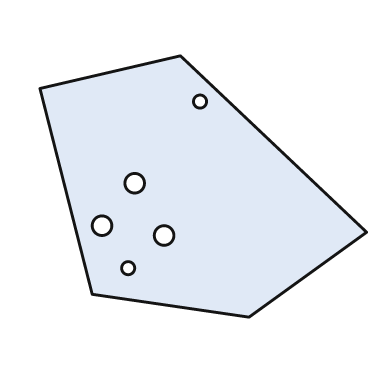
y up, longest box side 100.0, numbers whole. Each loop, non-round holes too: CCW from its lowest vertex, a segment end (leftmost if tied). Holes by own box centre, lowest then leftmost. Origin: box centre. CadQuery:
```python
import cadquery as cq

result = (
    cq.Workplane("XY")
    .moveTo(14.0, -40.0)
    .lineTo(50.0, -14.0)
    .lineTo(-7.0, 40.0)
    .lineTo(-50.0, 30.0)
    .lineTo(-34.0, -33.0)
    .close()
    .moveTo(-23.0, -25.0)
    .circle(2.0)
    .moveTo(-12.0, -15.0)
    .circle(3.0)
    .moveTo(-31.0, -12.0)
    .circle(3.0)
    .moveTo(-21.0, 1.0)
    .circle(3.0)
    .moveTo(-1.0, 26.0)
    .circle(2.0)
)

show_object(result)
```